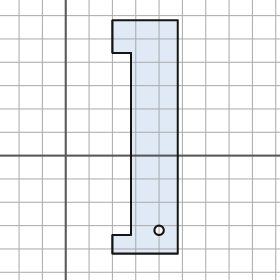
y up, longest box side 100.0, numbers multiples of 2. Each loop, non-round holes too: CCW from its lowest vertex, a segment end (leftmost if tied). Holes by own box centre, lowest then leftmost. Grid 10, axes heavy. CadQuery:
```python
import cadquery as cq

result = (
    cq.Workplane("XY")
    .moveTo(20.0, -42.0)
    .lineTo(48.0, -42.0)
    .lineTo(48.0, 58.0)
    .lineTo(20.0, 58.0)
    .lineTo(20.0, 44.0)
    .lineTo(28.0, 44.0)
    .lineTo(28.0, -34.0)
    .lineTo(20.0, -34.0)
    .close()
    .moveTo(40.0, -32.0)
    .circle(2.0)
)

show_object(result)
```